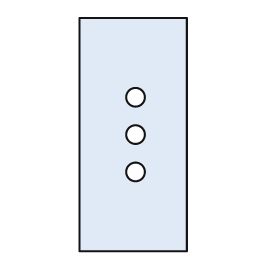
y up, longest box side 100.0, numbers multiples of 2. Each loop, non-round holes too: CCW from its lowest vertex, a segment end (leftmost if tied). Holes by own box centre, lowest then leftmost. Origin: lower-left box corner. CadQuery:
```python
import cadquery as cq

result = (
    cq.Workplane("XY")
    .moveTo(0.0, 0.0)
    .lineTo(46.0, 0.0)
    .lineTo(46.0, 100.0)
    .lineTo(0.0, 100.0)
    .close()
    .moveTo(24.0, 34.0)
    .circle(4.0)
    .moveTo(24.0, 50.0)
    .circle(4.0)
    .moveTo(24.0, 66.0)
    .circle(4.0)
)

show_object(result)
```